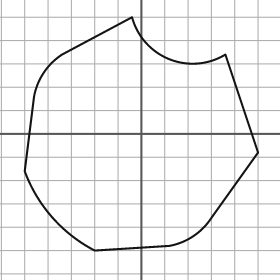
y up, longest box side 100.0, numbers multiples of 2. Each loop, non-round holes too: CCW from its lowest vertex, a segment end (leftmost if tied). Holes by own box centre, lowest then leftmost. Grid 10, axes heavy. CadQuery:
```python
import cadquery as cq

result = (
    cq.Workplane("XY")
    .moveTo(-20.0, -50.0)
    .lineTo(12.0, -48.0)
    .threePointArc((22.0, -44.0), (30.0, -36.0))
    .lineTo(50.0, -8.0)
    .lineTo(36.0, 34.0)
    .threePointArc((12.0, 32.0), (-4.0, 50.0))
    .lineTo(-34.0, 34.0)
    .threePointArc((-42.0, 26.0), (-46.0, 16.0))
    .lineTo(-50.0, -16.0)
    .threePointArc((-38.0, -36.0), (-20.0, -50.0))
    .close()
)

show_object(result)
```